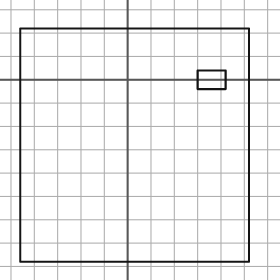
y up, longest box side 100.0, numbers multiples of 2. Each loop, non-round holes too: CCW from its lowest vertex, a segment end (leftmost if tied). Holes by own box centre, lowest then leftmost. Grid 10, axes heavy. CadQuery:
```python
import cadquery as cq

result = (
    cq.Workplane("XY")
    .moveTo(-46.0, -78.0)
    .lineTo(52.0, -78.0)
    .lineTo(52.0, 22.0)
    .lineTo(-46.0, 22.0)
    .close()
    .moveTo(30.0, -4.0)
    .lineTo(42.0, -4.0)
    .lineTo(42.0, 4.0)
    .lineTo(30.0, 4.0)
    .close()
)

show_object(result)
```